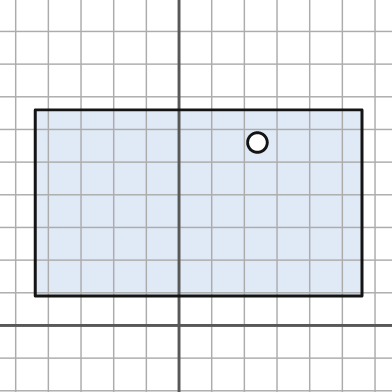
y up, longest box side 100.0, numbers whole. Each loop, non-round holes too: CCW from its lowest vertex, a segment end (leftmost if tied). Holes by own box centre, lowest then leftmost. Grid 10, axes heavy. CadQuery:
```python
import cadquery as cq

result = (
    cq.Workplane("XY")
    .moveTo(-44.0, 9.0)
    .lineTo(56.0, 9.0)
    .lineTo(56.0, 66.0)
    .lineTo(-44.0, 66.0)
    .close()
    .moveTo(24.0, 56.0)
    .circle(3.0)
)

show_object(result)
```